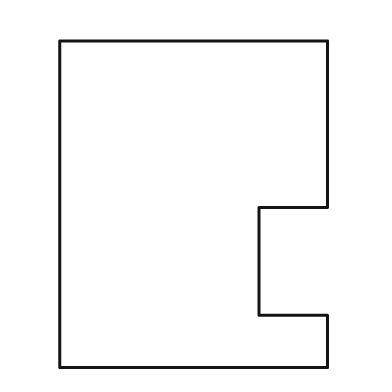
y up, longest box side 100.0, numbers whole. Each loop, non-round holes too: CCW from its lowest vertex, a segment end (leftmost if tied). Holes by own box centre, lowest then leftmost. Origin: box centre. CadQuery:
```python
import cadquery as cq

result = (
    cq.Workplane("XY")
    .moveTo(-41.0, -50.0)
    .lineTo(41.0, -50.0)
    .lineTo(41.0, -34.0)
    .lineTo(20.0, -34.0)
    .lineTo(20.0, -1.0)
    .lineTo(41.0, -1.0)
    .lineTo(41.0, 50.0)
    .lineTo(-41.0, 50.0)
    .close()
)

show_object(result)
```